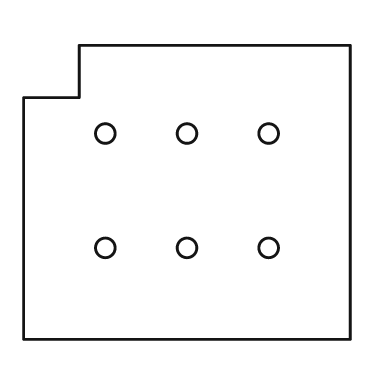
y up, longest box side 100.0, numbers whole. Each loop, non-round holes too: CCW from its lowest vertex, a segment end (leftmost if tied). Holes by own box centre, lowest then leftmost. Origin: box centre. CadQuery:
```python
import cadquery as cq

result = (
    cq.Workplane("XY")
    .moveTo(-50.0, -45.0)
    .lineTo(50.0, -45.0)
    .lineTo(50.0, 45.0)
    .lineTo(-33.0, 45.0)
    .lineTo(-33.0, 29.0)
    .lineTo(-50.0, 29.0)
    .close()
    .moveTo(-25.0, -17.0)
    .circle(3.0)
    .moveTo(0.0, -17.0)
    .circle(3.0)
    .moveTo(25.0, -17.0)
    .circle(3.0)
    .moveTo(-25.0, 18.0)
    .circle(3.0)
    .moveTo(0.0, 18.0)
    .circle(3.0)
    .moveTo(25.0, 18.0)
    .circle(3.0)
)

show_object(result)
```